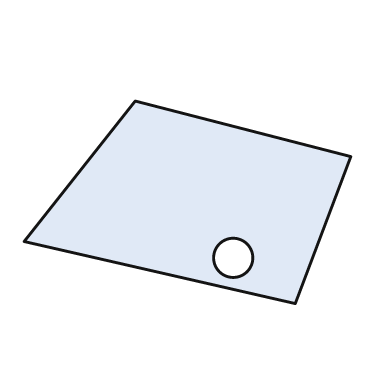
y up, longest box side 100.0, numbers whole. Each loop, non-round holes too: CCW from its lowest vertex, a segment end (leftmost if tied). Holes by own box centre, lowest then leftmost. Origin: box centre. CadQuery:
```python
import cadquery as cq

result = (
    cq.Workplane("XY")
    .moveTo(33.0, -31.0)
    .lineTo(50.0, 14.0)
    .lineTo(-16.0, 31.0)
    .lineTo(-50.0, -12.0)
    .close()
    .moveTo(14.0, -17.0)
    .circle(6.0)
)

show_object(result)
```